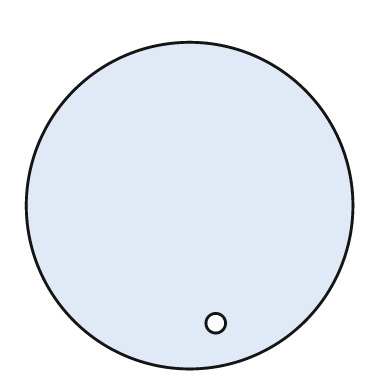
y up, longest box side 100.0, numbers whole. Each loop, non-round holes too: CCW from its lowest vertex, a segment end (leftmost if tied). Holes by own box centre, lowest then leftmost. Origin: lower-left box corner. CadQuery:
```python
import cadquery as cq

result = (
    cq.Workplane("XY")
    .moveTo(50.0, 50.0)
    .circle(50.0)
    .moveTo(58.0, 14.0)
    .circle(3.0)
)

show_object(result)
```